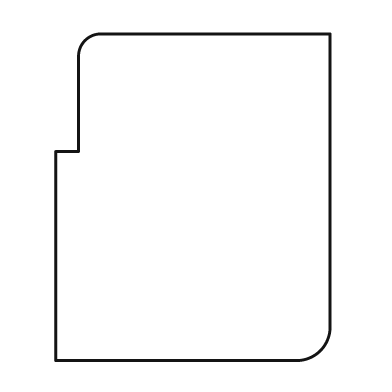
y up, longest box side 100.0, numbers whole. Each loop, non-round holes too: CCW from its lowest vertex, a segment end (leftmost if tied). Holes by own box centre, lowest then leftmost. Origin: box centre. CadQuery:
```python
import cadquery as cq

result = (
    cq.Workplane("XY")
    .moveTo(-42.0, -50.0)
    .lineTo(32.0, -50.0)
    .threePointArc((39.0, -47.0), (42.0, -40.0))
    .lineTo(42.0, 50.0)
    .lineTo(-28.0, 50.0)
    .threePointArc((-33.0, 48.0), (-35.0, 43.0))
    .lineTo(-35.0, 14.0)
    .lineTo(-42.0, 14.0)
    .close()
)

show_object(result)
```